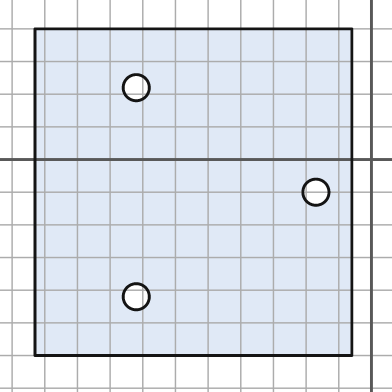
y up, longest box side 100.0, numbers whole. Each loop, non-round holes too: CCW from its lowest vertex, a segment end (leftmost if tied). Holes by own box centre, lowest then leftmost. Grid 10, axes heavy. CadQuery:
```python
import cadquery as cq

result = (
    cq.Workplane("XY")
    .moveTo(-103.0, -60.0)
    .lineTo(-6.0, -60.0)
    .lineTo(-6.0, 40.0)
    .lineTo(-103.0, 40.0)
    .close()
    .moveTo(-72.0, -42.0)
    .circle(4.0)
    .moveTo(-17.0, -10.0)
    .circle(4.0)
    .moveTo(-72.0, 22.0)
    .circle(4.0)
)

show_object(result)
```